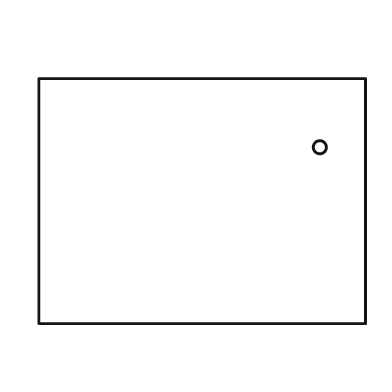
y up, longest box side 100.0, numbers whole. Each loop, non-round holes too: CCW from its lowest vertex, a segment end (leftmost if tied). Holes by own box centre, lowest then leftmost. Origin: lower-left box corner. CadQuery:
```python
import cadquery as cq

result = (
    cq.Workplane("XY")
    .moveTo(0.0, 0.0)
    .lineTo(100.0, 0.0)
    .lineTo(100.0, 75.0)
    .lineTo(0.0, 75.0)
    .close()
    .moveTo(86.0, 54.0)
    .circle(2.0)
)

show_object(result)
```